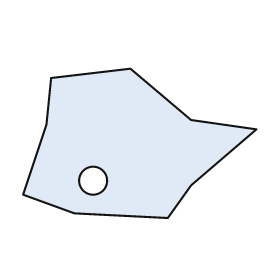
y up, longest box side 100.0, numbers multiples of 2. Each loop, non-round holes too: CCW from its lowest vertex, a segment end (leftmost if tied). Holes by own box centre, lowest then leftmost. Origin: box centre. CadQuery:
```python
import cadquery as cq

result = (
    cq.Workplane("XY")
    .moveTo(12.0, -32.0)
    .lineTo(22.0, -18.0)
    .lineTo(50.0, 6.0)
    .lineTo(22.0, 10.0)
    .lineTo(-4.0, 32.0)
    .lineTo(-38.0, 28.0)
    .lineTo(-40.0, 8.0)
    .lineTo(-50.0, -22.0)
    .lineTo(-28.0, -30.0)
    .close()
    .moveTo(-20.0, -16.0)
    .circle(6.0)
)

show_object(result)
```